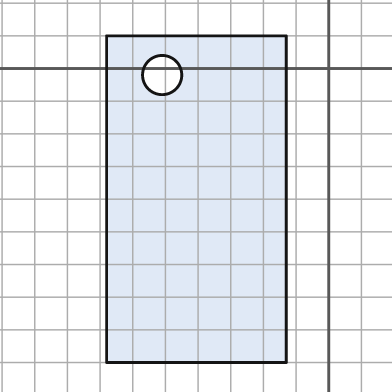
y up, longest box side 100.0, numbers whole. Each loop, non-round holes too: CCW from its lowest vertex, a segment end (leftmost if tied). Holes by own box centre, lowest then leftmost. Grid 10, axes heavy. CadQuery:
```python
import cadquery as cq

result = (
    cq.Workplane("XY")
    .moveTo(-68.0, -90.0)
    .lineTo(-13.0, -90.0)
    .lineTo(-13.0, 10.0)
    .lineTo(-68.0, 10.0)
    .close()
    .moveTo(-51.0, -2.0)
    .circle(6.0)
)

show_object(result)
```